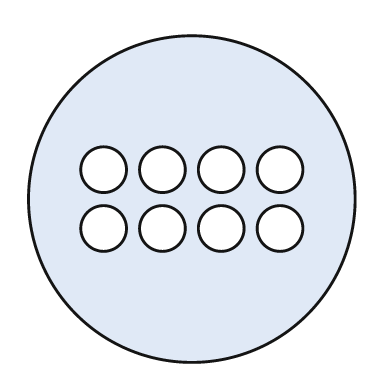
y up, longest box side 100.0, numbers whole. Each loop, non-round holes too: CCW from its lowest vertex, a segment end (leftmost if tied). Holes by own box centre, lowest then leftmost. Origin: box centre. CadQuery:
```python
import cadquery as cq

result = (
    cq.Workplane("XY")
    .moveTo(0.0, 0.0)
    .circle(50.0)
    .moveTo(-27.0, -9.0)
    .circle(7.0)
    .moveTo(-9.0, -9.0)
    .circle(7.0)
    .moveTo(9.0, -9.0)
    .circle(7.0)
    .moveTo(27.0, -9.0)
    .circle(7.0)
    .moveTo(-27.0, 9.0)
    .circle(7.0)
    .moveTo(-9.0, 9.0)
    .circle(7.0)
    .moveTo(9.0, 9.0)
    .circle(7.0)
    .moveTo(27.0, 9.0)
    .circle(7.0)
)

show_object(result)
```